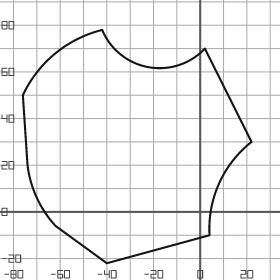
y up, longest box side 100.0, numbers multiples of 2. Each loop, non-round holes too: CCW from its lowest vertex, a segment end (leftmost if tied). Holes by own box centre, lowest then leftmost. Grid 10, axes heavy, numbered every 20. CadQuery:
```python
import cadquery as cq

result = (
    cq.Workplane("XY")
    .moveTo(-40.0, -22.0)
    .lineTo(4.0, -10.0)
    .threePointArc((8.0, 12.0), (22.0, 30.0))
    .lineTo(2.0, 70.0)
    .threePointArc((-22.0, 62.0), (-42.0, 78.0))
    .threePointArc((-62.0, 68.0), (-76.0, 50.0))
    .lineTo(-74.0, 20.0)
    .threePointArc((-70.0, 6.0), (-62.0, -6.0))
    .close()
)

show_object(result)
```